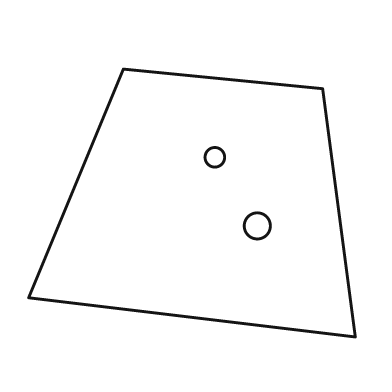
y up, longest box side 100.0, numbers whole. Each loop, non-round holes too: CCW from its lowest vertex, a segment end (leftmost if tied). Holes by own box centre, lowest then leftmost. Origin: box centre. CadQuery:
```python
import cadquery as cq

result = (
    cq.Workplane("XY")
    .moveTo(50.0, -41.0)
    .lineTo(40.0, 35.0)
    .lineTo(-21.0, 41.0)
    .lineTo(-50.0, -29.0)
    .close()
    .moveTo(20.0, -7.0)
    .circle(4.0)
    .moveTo(7.0, 14.0)
    .circle(3.0)
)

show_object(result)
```